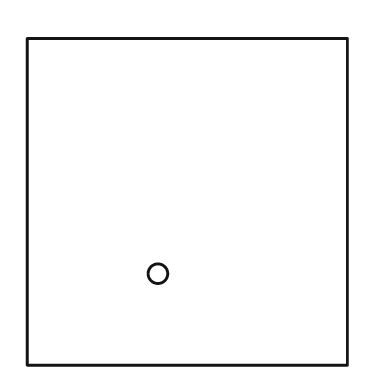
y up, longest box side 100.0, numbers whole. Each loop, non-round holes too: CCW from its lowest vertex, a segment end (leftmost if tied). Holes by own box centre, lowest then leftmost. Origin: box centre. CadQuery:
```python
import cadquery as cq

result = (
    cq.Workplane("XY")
    .moveTo(-49.0, -50.0)
    .lineTo(49.0, -50.0)
    .lineTo(49.0, 50.0)
    .lineTo(-49.0, 50.0)
    .close()
    .moveTo(-9.0, -22.0)
    .circle(3.0)
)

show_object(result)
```